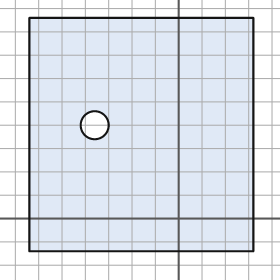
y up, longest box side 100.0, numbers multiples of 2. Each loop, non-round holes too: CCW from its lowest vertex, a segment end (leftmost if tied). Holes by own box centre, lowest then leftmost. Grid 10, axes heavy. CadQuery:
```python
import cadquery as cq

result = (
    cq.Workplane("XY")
    .moveTo(-64.0, -14.0)
    .lineTo(32.0, -14.0)
    .lineTo(32.0, 86.0)
    .lineTo(-64.0, 86.0)
    .close()
    .moveTo(-36.0, 40.0)
    .circle(6.0)
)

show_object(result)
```